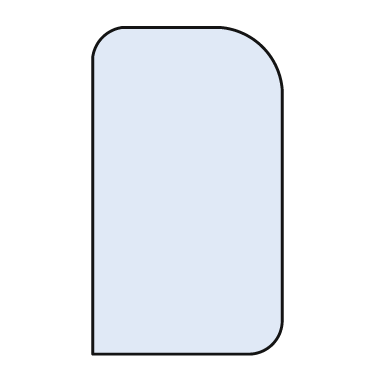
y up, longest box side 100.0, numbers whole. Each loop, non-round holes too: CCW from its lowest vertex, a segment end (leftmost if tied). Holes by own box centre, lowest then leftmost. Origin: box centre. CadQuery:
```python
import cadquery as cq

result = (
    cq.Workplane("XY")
    .moveTo(-29.0, -50.0)
    .lineTo(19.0, -50.0)
    .threePointArc((26.0, -47.0), (29.0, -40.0))
    .lineTo(29.0, 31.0)
    .threePointArc((23.0, 44.0), (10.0, 50.0))
    .lineTo(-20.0, 50.0)
    .threePointArc((-26.0, 47.0), (-29.0, 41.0))
    .close()
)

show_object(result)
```